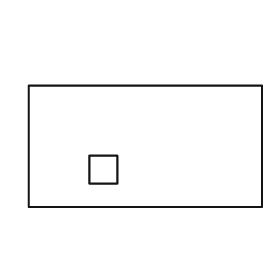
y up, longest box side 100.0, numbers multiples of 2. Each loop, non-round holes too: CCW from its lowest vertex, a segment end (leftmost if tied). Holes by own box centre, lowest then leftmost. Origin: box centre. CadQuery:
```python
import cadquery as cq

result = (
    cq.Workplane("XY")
    .moveTo(-50.0, -26.0)
    .lineTo(50.0, -26.0)
    .lineTo(50.0, 26.0)
    .lineTo(-50.0, 26.0)
    .close()
    .moveTo(-24.0, -16.0)
    .lineTo(-12.0, -16.0)
    .lineTo(-12.0, -4.0)
    .lineTo(-24.0, -4.0)
    .close()
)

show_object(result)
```